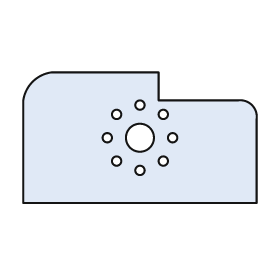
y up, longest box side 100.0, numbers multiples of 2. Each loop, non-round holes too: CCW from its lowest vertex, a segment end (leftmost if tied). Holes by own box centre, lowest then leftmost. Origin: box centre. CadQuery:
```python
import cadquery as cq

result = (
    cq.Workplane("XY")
    .moveTo(-50.0, -28.0)
    .lineTo(50.0, -28.0)
    .lineTo(50.0, 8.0)
    .threePointArc((48.0, 14.0), (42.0, 16.0))
    .lineTo(8.0, 16.0)
    .lineTo(8.0, 28.0)
    .lineTo(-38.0, 28.0)
    .threePointArc((-46.0, 24.0), (-50.0, 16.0))
    .close()
    .moveTo(0.0, -14.0)
    .circle(2.0)
    .moveTo(-10.0, -10.0)
    .circle(2.0)
    .moveTo(10.0, -10.0)
    .circle(2.0)
    .moveTo(-14.0, 0.0)
    .circle(2.0)
    .moveTo(0.0, 0.0)
    .circle(6.0)
    .moveTo(14.0, 0.0)
    .circle(2.0)
    .moveTo(-10.0, 10.0)
    .circle(2.0)
    .moveTo(10.0, 10.0)
    .circle(2.0)
    .moveTo(0.0, 14.0)
    .circle(2.0)
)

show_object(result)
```